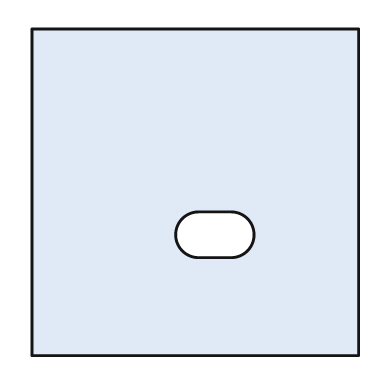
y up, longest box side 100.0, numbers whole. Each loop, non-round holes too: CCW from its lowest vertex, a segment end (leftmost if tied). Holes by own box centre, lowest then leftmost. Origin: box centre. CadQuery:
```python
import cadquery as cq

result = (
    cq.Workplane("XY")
    .moveTo(-50.0, -50.0)
    .lineTo(50.0, -50.0)
    .lineTo(50.0, 50.0)
    .lineTo(-50.0, 50.0)
    .close()
    .moveTo(1.0, -20.0)
    .lineTo(11.0, -20.0)
    .threePointArc((18.0, -13.0), (11.0, -6.0))
    .lineTo(1.0, -6.0)
    .threePointArc((-6.0, -13.0), (1.0, -20.0))
    .close()
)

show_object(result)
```